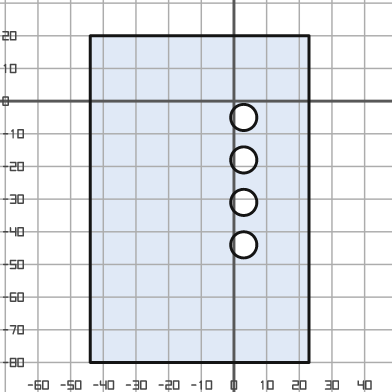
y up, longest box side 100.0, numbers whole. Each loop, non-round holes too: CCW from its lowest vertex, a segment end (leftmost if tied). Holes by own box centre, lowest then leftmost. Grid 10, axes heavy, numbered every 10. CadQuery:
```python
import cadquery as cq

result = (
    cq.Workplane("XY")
    .moveTo(-44.0, -80.0)
    .lineTo(23.0, -80.0)
    .lineTo(23.0, 20.0)
    .lineTo(-44.0, 20.0)
    .close()
    .moveTo(3.0, -44.0)
    .circle(4.0)
    .moveTo(3.0, -31.0)
    .circle(4.0)
    .moveTo(3.0, -18.0)
    .circle(4.0)
    .moveTo(3.0, -5.0)
    .circle(4.0)
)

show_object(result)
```